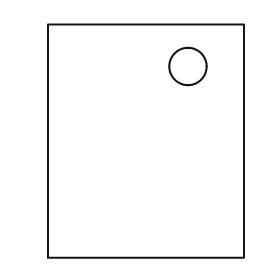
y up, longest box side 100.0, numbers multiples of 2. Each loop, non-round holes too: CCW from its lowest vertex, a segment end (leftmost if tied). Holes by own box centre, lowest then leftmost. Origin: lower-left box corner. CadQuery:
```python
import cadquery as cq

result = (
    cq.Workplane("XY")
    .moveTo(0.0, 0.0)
    .lineTo(84.0, 0.0)
    .lineTo(84.0, 100.0)
    .lineTo(0.0, 100.0)
    .close()
    .moveTo(60.0, 82.0)
    .circle(8.0)
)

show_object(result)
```